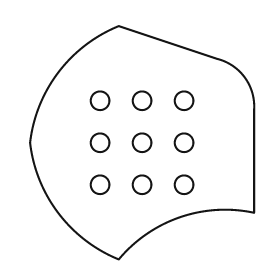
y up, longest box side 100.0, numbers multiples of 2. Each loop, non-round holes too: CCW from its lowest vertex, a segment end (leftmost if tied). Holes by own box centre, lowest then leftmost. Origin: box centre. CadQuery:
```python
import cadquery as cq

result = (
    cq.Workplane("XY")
    .moveTo(-10.0, -50.0)
    .threePointArc((16.0, -32.0), (48.0, -30.0))
    .lineTo(48.0, 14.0)
    .threePointArc((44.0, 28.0), (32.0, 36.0))
    .lineTo(-10.0, 50.0)
    .threePointArc((-36.0, 30.0), (-48.0, 0.0))
    .threePointArc((-36.0, -30.0), (-10.0, -50.0))
    .close()
    .moveTo(-18.0, -18.0)
    .circle(4.0)
    .moveTo(0.0, -18.0)
    .circle(4.0)
    .moveTo(18.0, -18.0)
    .circle(4.0)
    .moveTo(-18.0, 0.0)
    .circle(4.0)
    .moveTo(0.0, 0.0)
    .circle(4.0)
    .moveTo(18.0, 0.0)
    .circle(4.0)
    .moveTo(-18.0, 18.0)
    .circle(4.0)
    .moveTo(0.0, 18.0)
    .circle(4.0)
    .moveTo(18.0, 18.0)
    .circle(4.0)
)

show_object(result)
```